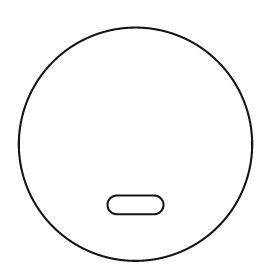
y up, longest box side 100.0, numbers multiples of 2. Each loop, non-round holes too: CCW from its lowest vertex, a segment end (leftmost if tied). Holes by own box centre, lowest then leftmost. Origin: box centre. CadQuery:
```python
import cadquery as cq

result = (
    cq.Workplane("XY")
    .moveTo(0.0, 0.0)
    .circle(50.0)
    .moveTo(-8.0, -30.0)
    .lineTo(8.0, -30.0)
    .threePointArc((12.0, -26.0), (8.0, -22.0))
    .lineTo(-8.0, -22.0)
    .threePointArc((-12.0, -26.0), (-8.0, -30.0))
    .close()
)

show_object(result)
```